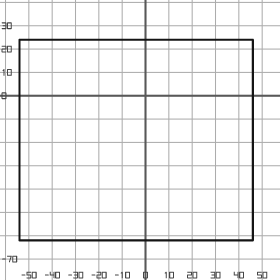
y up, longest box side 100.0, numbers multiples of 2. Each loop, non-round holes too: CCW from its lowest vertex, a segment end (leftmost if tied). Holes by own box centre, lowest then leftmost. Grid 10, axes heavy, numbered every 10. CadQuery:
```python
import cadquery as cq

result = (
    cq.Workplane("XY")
    .moveTo(-54.0, -62.0)
    .lineTo(46.0, -62.0)
    .lineTo(46.0, 24.0)
    .lineTo(-54.0, 24.0)
    .close()
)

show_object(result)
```